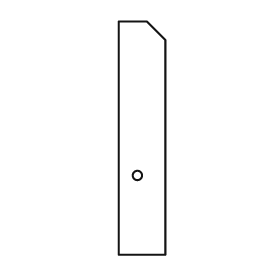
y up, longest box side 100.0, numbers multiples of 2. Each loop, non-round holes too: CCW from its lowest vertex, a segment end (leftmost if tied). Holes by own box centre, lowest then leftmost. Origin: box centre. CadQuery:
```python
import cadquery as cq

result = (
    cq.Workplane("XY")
    .moveTo(-10.0, -50.0)
    .lineTo(10.0, -50.0)
    .lineTo(10.0, 42.0)
    .lineTo(2.0, 50.0)
    .lineTo(-10.0, 50.0)
    .close()
    .moveTo(-2.0, -16.0)
    .circle(2.0)
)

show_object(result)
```